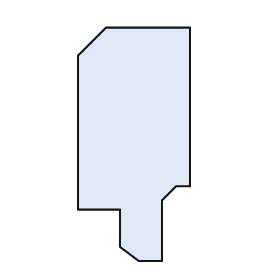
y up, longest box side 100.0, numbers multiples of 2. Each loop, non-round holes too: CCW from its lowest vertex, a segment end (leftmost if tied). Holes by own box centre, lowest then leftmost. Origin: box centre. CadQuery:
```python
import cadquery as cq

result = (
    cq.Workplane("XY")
    .moveTo(2.0, -50.0)
    .lineTo(12.0, -50.0)
    .lineTo(12.0, -24.0)
    .lineTo(18.0, -18.0)
    .lineTo(24.0, -18.0)
    .lineTo(24.0, 50.0)
    .lineTo(-12.0, 50.0)
    .lineTo(-24.0, 38.0)
    .lineTo(-24.0, -28.0)
    .lineTo(-6.0, -28.0)
    .lineTo(-6.0, -44.0)
    .close()
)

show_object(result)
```